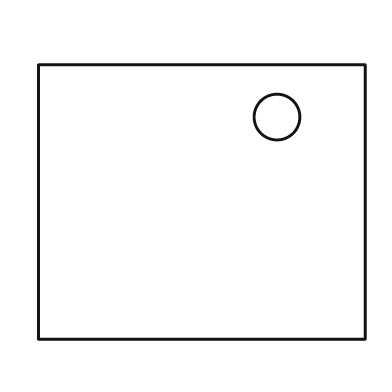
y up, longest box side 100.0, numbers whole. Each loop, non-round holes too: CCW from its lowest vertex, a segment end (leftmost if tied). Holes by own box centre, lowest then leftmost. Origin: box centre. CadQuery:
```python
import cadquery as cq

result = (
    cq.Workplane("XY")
    .moveTo(-50.0, -42.0)
    .lineTo(50.0, -42.0)
    .lineTo(50.0, 42.0)
    .lineTo(-50.0, 42.0)
    .close()
    .moveTo(23.0, 26.0)
    .circle(7.0)
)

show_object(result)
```